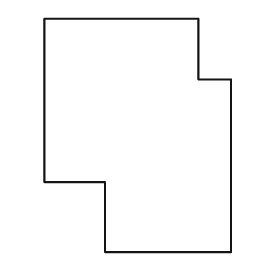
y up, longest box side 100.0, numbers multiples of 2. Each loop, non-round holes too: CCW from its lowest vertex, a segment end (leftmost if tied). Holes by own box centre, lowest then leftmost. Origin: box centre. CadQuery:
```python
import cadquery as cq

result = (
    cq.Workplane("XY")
    .moveTo(-14.0, -50.0)
    .lineTo(40.0, -50.0)
    .lineTo(40.0, 24.0)
    .lineTo(26.0, 24.0)
    .lineTo(26.0, 50.0)
    .lineTo(-40.0, 50.0)
    .lineTo(-40.0, -20.0)
    .lineTo(-14.0, -20.0)
    .close()
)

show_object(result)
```